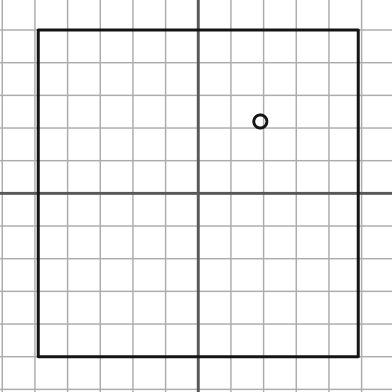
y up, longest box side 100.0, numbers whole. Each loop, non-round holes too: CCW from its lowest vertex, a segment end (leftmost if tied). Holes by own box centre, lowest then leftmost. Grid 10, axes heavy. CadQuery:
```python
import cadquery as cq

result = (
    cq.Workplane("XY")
    .moveTo(-49.0, -50.0)
    .lineTo(49.0, -50.0)
    .lineTo(49.0, 50.0)
    .lineTo(-49.0, 50.0)
    .close()
    .moveTo(19.0, 22.0)
    .circle(2.0)
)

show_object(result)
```